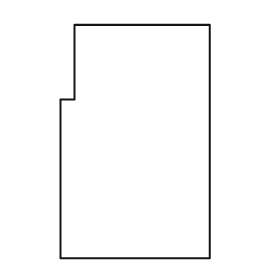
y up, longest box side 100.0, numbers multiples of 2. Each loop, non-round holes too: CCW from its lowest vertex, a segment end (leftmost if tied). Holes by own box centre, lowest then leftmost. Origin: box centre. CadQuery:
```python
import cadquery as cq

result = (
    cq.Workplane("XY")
    .moveTo(-32.0, -50.0)
    .lineTo(32.0, -50.0)
    .lineTo(32.0, 50.0)
    .lineTo(-26.0, 50.0)
    .lineTo(-26.0, 18.0)
    .lineTo(-32.0, 18.0)
    .close()
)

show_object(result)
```